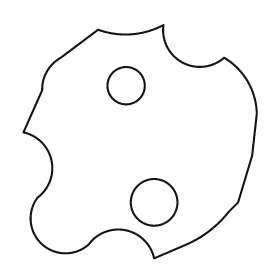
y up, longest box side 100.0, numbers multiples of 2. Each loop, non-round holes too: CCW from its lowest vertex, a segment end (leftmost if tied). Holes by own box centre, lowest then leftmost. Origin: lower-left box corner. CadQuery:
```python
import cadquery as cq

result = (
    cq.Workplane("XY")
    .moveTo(56.0, 0.0)
    .lineTo(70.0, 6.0)
    .threePointArc((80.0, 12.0), (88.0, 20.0))
    .lineTo(92.0, 24.0)
    .lineTo(98.0, 44.0)
    .lineTo(100.0, 62.0)
    .threePointArc((96.0, 76.0), (86.0, 86.0))
    .threePointArc((68.0, 84.0), (60.0, 100.0))
    .threePointArc((46.0, 96.0), (32.0, 98.0))
    .lineTo(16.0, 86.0)
    .threePointArc((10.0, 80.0), (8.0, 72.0))
    .lineTo(0.0, 54.0)
    .threePointArc((12.0, 42.0), (6.0, 26.0))
    .threePointArc((8.0, 6.0), (28.0, 6.0))
    .threePointArc((44.0, 12.0), (56.0, 0.0))
    .close()
    .moveTo(56.0, 24.0)
    .circle(10.0)
    .moveTo(44.0, 74.0)
    .circle(8.0)
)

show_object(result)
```